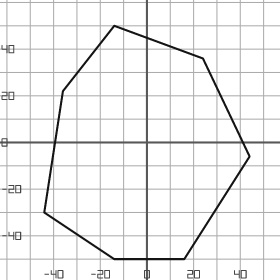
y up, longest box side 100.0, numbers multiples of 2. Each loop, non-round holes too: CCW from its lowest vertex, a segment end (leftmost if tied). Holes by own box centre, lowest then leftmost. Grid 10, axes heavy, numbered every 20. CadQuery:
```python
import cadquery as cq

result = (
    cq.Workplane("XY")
    .moveTo(-14.0, -50.0)
    .lineTo(16.0, -50.0)
    .lineTo(44.0, -6.0)
    .lineTo(24.0, 36.0)
    .lineTo(-14.0, 50.0)
    .lineTo(-36.0, 22.0)
    .lineTo(-44.0, -30.0)
    .close()
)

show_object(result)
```